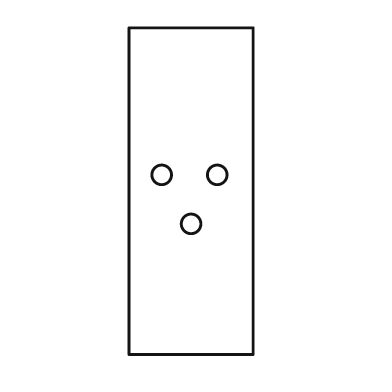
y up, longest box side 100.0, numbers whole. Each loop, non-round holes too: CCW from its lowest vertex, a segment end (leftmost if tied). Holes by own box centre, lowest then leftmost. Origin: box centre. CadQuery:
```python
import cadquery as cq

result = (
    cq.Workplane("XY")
    .moveTo(-19.0, -50.0)
    .lineTo(19.0, -50.0)
    .lineTo(19.0, 50.0)
    .lineTo(-19.0, 50.0)
    .close()
    .moveTo(0.0, -10.0)
    .circle(3.0)
    .moveTo(-9.0, 5.0)
    .circle(3.0)
    .moveTo(8.0, 5.0)
    .circle(3.0)
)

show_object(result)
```